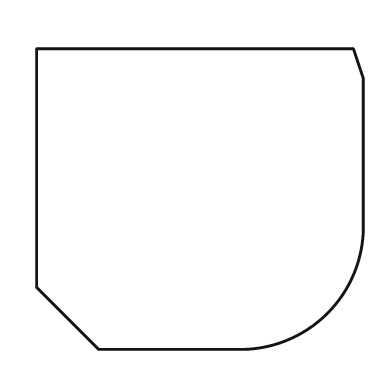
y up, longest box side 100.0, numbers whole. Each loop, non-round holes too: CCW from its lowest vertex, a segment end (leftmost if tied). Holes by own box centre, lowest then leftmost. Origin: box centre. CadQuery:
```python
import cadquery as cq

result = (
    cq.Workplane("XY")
    .moveTo(-31.0, -46.0)
    .lineTo(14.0, -46.0)
    .threePointArc((39.0, -35.0), (50.0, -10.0))
    .lineTo(50.0, 37.0)
    .lineTo(47.0, 46.0)
    .lineTo(-50.0, 46.0)
    .lineTo(-50.0, -27.0)
    .close()
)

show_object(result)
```